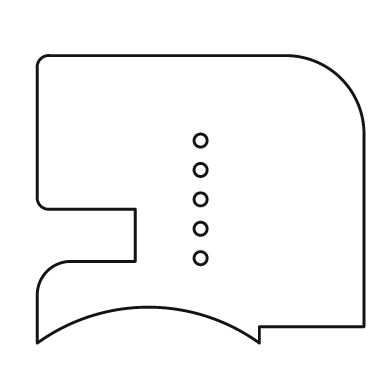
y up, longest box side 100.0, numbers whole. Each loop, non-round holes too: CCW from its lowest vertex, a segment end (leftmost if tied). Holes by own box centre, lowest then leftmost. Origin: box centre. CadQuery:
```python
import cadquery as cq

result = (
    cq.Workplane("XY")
    .moveTo(-50.0, -44.0)
    .threePointArc((-16.0, -33.0), (18.0, -44.0))
    .lineTo(18.0, -39.0)
    .lineTo(50.0, -39.0)
    .lineTo(50.0, 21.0)
    .threePointArc((43.0, 37.0), (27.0, 44.0))
    .lineTo(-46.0, 44.0)
    .threePointArc((-49.0, 43.0), (-50.0, 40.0))
    .lineTo(-50.0, 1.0)
    .threePointArc((-49.0, -2.0), (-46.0, -3.0))
    .lineTo(-20.0, -3.0)
    .lineTo(-20.0, -19.0)
    .lineTo(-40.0, -19.0)
    .threePointArc((-47.0, -22.0), (-50.0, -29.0))
    .close()
    .moveTo(0.0, -18.0)
    .circle(2.0)
    .moveTo(0.0, -9.0)
    .circle(2.0)
    .moveTo(0.0, 0.0)
    .circle(2.0)
    .moveTo(0.0, 9.0)
    .circle(2.0)
    .moveTo(0.0, 18.0)
    .circle(2.0)
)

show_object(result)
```